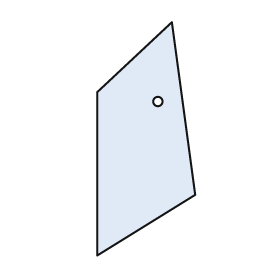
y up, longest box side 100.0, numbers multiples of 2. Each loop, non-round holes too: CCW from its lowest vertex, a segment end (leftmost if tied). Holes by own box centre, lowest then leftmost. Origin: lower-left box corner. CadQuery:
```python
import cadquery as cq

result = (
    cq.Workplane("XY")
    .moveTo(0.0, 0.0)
    .lineTo(42.0, 26.0)
    .lineTo(32.0, 100.0)
    .lineTo(0.0, 70.0)
    .close()
    .moveTo(26.0, 66.0)
    .circle(2.0)
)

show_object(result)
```